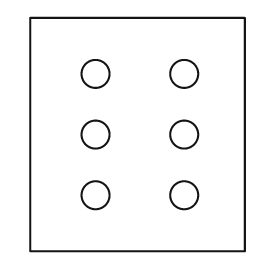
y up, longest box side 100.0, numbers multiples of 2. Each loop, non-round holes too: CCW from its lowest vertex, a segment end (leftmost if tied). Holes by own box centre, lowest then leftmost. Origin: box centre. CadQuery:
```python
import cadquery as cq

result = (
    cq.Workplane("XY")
    .moveTo(-46.0, -50.0)
    .lineTo(46.0, -50.0)
    .lineTo(46.0, 50.0)
    .lineTo(-46.0, 50.0)
    .close()
    .moveTo(-18.0, -26.0)
    .circle(6.0)
    .moveTo(20.0, -26.0)
    .circle(6.0)
    .moveTo(-18.0, 0.0)
    .circle(6.0)
    .moveTo(20.0, 0.0)
    .circle(6.0)
    .moveTo(-18.0, 26.0)
    .circle(6.0)
    .moveTo(20.0, 26.0)
    .circle(6.0)
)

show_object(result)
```